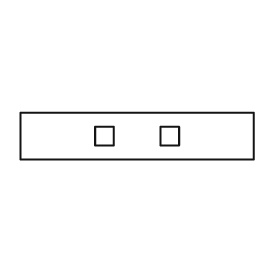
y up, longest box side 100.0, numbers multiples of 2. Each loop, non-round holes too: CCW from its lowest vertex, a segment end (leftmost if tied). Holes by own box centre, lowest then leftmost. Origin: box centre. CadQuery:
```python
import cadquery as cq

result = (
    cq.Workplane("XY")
    .moveTo(-50.0, -10.0)
    .lineTo(50.0, -10.0)
    .lineTo(50.0, 10.0)
    .lineTo(-50.0, 10.0)
    .close()
    .moveTo(-18.0, -4.0)
    .lineTo(-10.0, -4.0)
    .lineTo(-10.0, 4.0)
    .lineTo(-18.0, 4.0)
    .close()
    .moveTo(10.0, -4.0)
    .lineTo(18.0, -4.0)
    .lineTo(18.0, 4.0)
    .lineTo(10.0, 4.0)
    .close()
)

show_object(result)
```